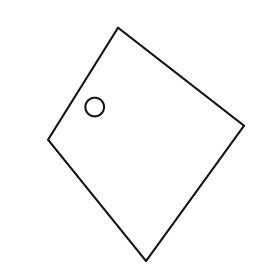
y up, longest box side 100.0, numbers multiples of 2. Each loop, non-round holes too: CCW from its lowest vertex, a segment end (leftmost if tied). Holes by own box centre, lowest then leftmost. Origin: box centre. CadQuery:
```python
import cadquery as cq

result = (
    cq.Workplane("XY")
    .moveTo(0.0, -50.0)
    .lineTo(42.0, 8.0)
    .lineTo(-12.0, 50.0)
    .lineTo(-42.0, 2.0)
    .close()
    .moveTo(-22.0, 16.0)
    .circle(4.0)
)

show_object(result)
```